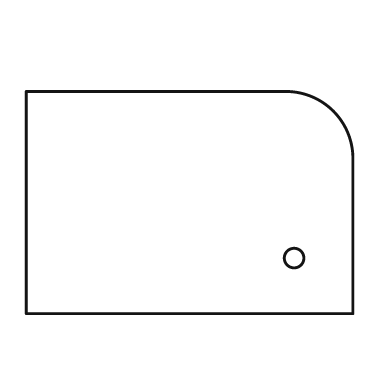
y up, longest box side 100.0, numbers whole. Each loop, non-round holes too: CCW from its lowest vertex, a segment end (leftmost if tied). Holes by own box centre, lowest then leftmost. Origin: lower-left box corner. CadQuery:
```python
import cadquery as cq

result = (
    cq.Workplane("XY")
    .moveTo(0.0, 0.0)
    .lineTo(100.0, 0.0)
    .lineTo(100.0, 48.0)
    .threePointArc((94.0, 62.0), (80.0, 68.0))
    .lineTo(0.0, 68.0)
    .close()
    .moveTo(82.0, 17.0)
    .circle(3.0)
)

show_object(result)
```